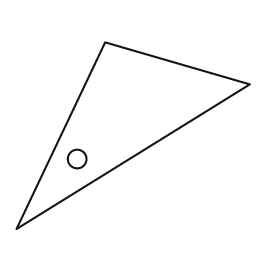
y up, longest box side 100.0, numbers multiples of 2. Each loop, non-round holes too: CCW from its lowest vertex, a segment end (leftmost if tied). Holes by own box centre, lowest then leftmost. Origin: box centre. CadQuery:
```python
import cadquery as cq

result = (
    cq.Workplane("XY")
    .moveTo(-50.0, -40.0)
    .lineTo(50.0, 22.0)
    .lineTo(-12.0, 40.0)
    .close()
    .moveTo(-24.0, -10.0)
    .circle(4.0)
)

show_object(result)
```